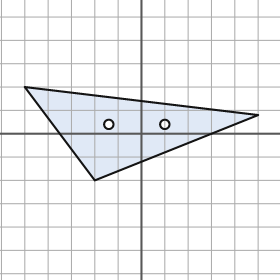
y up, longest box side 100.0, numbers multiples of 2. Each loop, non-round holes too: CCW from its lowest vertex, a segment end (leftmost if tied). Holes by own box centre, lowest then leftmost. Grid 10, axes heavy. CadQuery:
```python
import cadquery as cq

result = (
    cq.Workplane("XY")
    .moveTo(-20.0, -20.0)
    .lineTo(50.0, 8.0)
    .lineTo(-50.0, 20.0)
    .close()
    .moveTo(-14.0, 4.0)
    .circle(2.0)
    .moveTo(10.0, 4.0)
    .circle(2.0)
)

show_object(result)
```